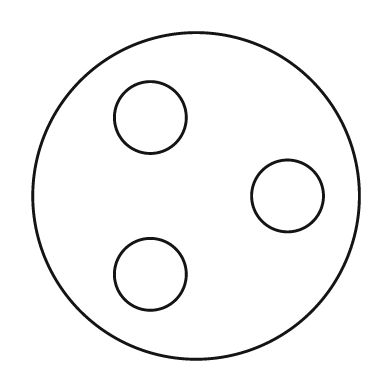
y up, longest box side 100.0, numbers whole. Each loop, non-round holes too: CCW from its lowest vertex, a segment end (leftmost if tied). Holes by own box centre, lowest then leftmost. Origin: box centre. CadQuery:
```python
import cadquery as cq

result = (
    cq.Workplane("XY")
    .moveTo(0.0, 0.0)
    .circle(50.0)
    .moveTo(-14.0, -24.0)
    .circle(11.0)
    .moveTo(28.0, 0.0)
    .circle(11.0)
    .moveTo(-14.0, 24.0)
    .circle(11.0)
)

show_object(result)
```